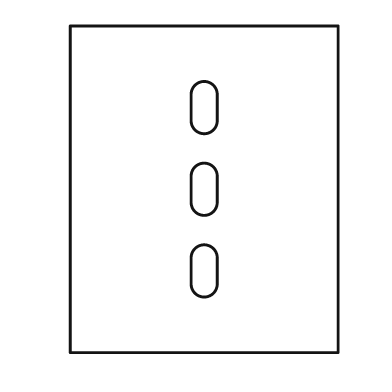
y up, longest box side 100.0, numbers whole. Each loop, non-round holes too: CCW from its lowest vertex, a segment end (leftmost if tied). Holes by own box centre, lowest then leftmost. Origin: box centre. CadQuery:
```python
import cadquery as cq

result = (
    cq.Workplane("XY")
    .moveTo(-41.0, -50.0)
    .lineTo(41.0, -50.0)
    .lineTo(41.0, 50.0)
    .lineTo(-41.0, 50.0)
    .close()
    .moveTo(-4.0, -29.0)
    .threePointArc((0.0, -33.0), (4.0, -29.0))
    .lineTo(4.0, -21.0)
    .threePointArc((0.0, -17.0), (-4.0, -21.0))
    .close()
    .moveTo(-4.0, -4.0)
    .threePointArc((0.0, -8.0), (4.0, -4.0))
    .lineTo(4.0, 4.0)
    .threePointArc((0.0, 8.0), (-4.0, 4.0))
    .close()
    .moveTo(-4.0, 21.0)
    .threePointArc((0.0, 17.0), (4.0, 21.0))
    .lineTo(4.0, 29.0)
    .threePointArc((0.0, 33.0), (-4.0, 29.0))
    .close()
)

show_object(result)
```